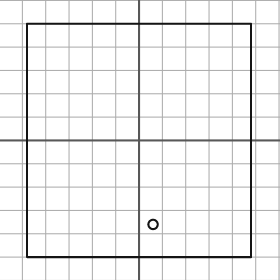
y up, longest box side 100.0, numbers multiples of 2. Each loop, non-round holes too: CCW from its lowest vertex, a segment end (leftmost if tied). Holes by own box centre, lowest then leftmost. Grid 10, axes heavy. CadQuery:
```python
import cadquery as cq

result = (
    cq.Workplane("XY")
    .moveTo(-48.0, -50.0)
    .lineTo(48.0, -50.0)
    .lineTo(48.0, 50.0)
    .lineTo(-48.0, 50.0)
    .close()
    .moveTo(6.0, -36.0)
    .circle(2.0)
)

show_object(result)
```